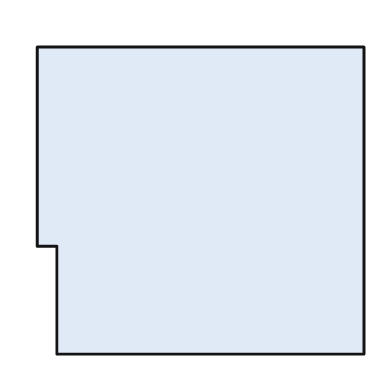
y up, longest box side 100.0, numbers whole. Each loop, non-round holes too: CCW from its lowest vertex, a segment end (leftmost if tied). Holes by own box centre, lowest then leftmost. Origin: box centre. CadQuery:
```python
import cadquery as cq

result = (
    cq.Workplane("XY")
    .moveTo(-44.0, -47.0)
    .lineTo(50.0, -47.0)
    .lineTo(50.0, 47.0)
    .lineTo(-50.0, 47.0)
    .lineTo(-50.0, -14.0)
    .lineTo(-44.0, -14.0)
    .close()
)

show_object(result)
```